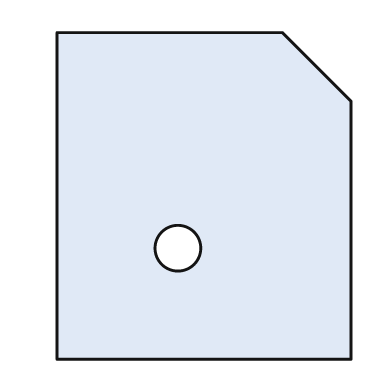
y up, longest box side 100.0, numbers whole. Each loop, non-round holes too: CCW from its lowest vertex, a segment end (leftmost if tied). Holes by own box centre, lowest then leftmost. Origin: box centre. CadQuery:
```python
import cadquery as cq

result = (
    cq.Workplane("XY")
    .moveTo(-45.0, -50.0)
    .lineTo(45.0, -50.0)
    .lineTo(45.0, 29.0)
    .lineTo(24.0, 50.0)
    .lineTo(-45.0, 50.0)
    .close()
    .moveTo(-8.0, -16.0)
    .circle(7.0)
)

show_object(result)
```